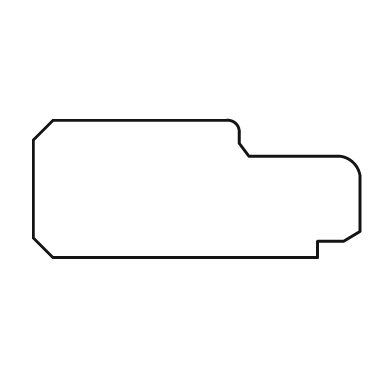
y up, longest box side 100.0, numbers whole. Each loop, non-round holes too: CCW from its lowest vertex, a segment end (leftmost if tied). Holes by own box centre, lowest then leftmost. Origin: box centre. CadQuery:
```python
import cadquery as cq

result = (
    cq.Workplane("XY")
    .moveTo(-44.0, -21.0)
    .lineTo(37.0, -21.0)
    .lineTo(37.0, -16.0)
    .lineTo(45.0, -16.0)
    .lineTo(50.0, -13.0)
    .lineTo(50.0, 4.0)
    .threePointArc((48.0, 8.0), (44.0, 10.0))
    .lineTo(16.0, 10.0)
    .lineTo(13.0, 14.0)
    .lineTo(13.0, 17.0)
    .threePointArc((12.0, 20.0), (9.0, 21.0))
    .lineTo(-44.0, 21.0)
    .lineTo(-50.0, 15.0)
    .lineTo(-50.0, -15.0)
    .close()
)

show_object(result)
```